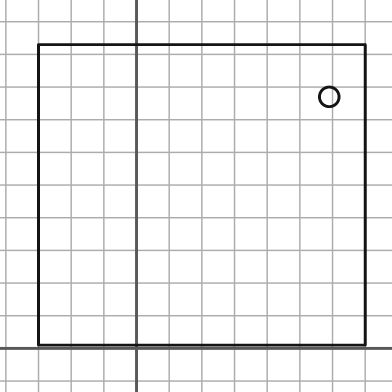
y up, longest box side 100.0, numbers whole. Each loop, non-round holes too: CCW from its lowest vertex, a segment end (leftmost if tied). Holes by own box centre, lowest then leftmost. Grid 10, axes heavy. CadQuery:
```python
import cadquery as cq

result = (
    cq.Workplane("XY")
    .moveTo(-30.0, 1.0)
    .lineTo(70.0, 1.0)
    .lineTo(70.0, 93.0)
    .lineTo(-30.0, 93.0)
    .close()
    .moveTo(59.0, 77.0)
    .circle(3.0)
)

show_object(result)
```